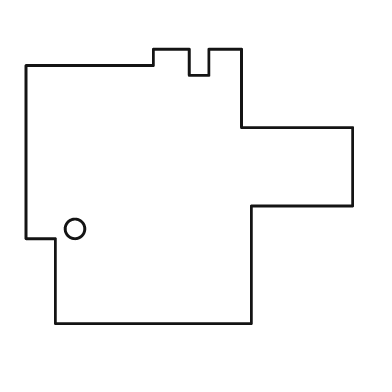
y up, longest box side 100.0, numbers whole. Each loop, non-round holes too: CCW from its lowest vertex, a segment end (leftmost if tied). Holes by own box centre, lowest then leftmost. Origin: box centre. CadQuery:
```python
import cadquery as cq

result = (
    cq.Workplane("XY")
    .moveTo(-41.0, -42.0)
    .lineTo(19.0, -42.0)
    .lineTo(19.0, -6.0)
    .lineTo(50.0, -6.0)
    .lineTo(50.0, 18.0)
    .lineTo(16.0, 18.0)
    .lineTo(16.0, 42.0)
    .lineTo(6.0, 42.0)
    .lineTo(6.0, 34.0)
    .lineTo(0.0, 34.0)
    .lineTo(0.0, 42.0)
    .lineTo(-11.0, 42.0)
    .lineTo(-11.0, 37.0)
    .lineTo(-50.0, 37.0)
    .lineTo(-50.0, -16.0)
    .lineTo(-41.0, -16.0)
    .close()
    .moveTo(-35.0, -13.0)
    .circle(3.0)
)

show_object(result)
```